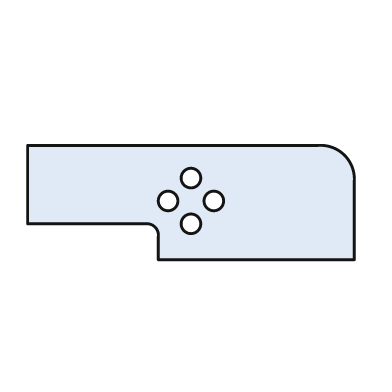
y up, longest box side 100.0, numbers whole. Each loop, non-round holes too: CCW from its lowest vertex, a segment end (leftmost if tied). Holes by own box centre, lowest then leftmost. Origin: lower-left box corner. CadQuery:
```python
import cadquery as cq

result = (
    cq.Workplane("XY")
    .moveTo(40.0, 0.0)
    .lineTo(100.0, 0.0)
    .lineTo(100.0, 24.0)
    .threePointArc((97.0, 32.0), (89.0, 35.0))
    .lineTo(0.0, 35.0)
    .lineTo(0.0, 11.0)
    .lineTo(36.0, 11.0)
    .threePointArc((39.0, 10.0), (40.0, 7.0))
    .close()
    .moveTo(50.0, 11.0)
    .circle(3.0)
    .moveTo(43.0, 18.0)
    .circle(3.0)
    .moveTo(57.0, 18.0)
    .circle(3.0)
    .moveTo(50.0, 25.0)
    .circle(3.0)
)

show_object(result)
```